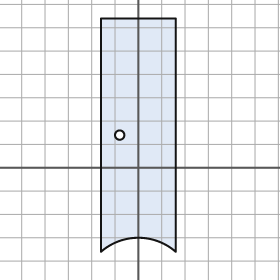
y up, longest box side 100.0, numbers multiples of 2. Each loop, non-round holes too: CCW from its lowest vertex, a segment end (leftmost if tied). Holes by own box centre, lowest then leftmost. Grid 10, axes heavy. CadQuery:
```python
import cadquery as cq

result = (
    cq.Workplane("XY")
    .moveTo(-16.0, -36.0)
    .threePointArc((0.0, -30.0), (16.0, -36.0))
    .lineTo(16.0, 64.0)
    .lineTo(-16.0, 64.0)
    .close()
    .moveTo(-8.0, 14.0)
    .circle(2.0)
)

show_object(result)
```